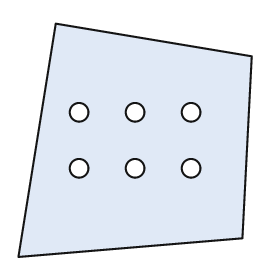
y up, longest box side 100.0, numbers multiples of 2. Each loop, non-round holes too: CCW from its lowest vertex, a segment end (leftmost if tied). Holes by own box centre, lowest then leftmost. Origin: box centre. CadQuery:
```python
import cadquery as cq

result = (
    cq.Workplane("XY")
    .moveTo(-50.0, -50.0)
    .lineTo(46.0, -42.0)
    .lineTo(50.0, 36.0)
    .lineTo(-34.0, 50.0)
    .close()
    .moveTo(-24.0, -12.0)
    .circle(4.0)
    .moveTo(0.0, -12.0)
    .circle(4.0)
    .moveTo(24.0, -12.0)
    .circle(4.0)
    .moveTo(-24.0, 12.0)
    .circle(4.0)
    .moveTo(0.0, 12.0)
    .circle(4.0)
    .moveTo(24.0, 12.0)
    .circle(4.0)
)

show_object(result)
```